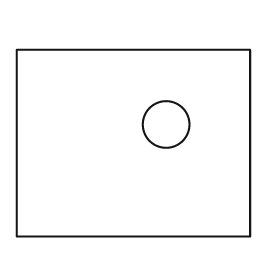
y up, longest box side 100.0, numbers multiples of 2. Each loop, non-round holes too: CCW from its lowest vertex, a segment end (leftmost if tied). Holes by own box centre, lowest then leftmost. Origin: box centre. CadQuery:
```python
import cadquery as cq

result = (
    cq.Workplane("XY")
    .moveTo(-50.0, -40.0)
    .lineTo(50.0, -40.0)
    .lineTo(50.0, 40.0)
    .lineTo(-50.0, 40.0)
    .close()
    .moveTo(14.0, 8.0)
    .circle(10.0)
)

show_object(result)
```